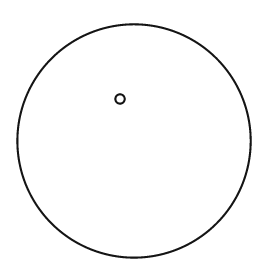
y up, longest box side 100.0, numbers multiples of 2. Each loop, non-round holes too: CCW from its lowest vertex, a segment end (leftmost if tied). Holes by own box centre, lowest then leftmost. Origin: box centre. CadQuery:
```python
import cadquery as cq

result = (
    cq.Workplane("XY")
    .moveTo(0.0, 0.0)
    .circle(50.0)
    .moveTo(-6.0, 18.0)
    .circle(2.0)
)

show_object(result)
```